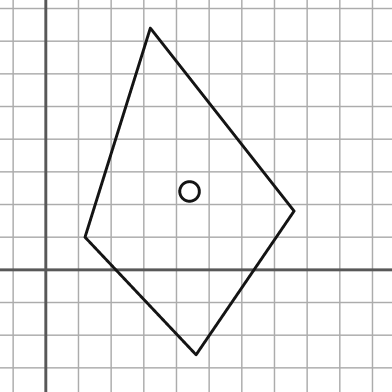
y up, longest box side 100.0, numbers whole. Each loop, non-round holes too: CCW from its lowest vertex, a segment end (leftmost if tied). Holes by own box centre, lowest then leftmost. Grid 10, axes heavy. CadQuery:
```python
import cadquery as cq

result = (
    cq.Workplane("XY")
    .moveTo(46.0, -26.0)
    .lineTo(76.0, 18.0)
    .lineTo(32.0, 74.0)
    .lineTo(12.0, 10.0)
    .close()
    .moveTo(44.0, 24.0)
    .circle(3.0)
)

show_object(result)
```